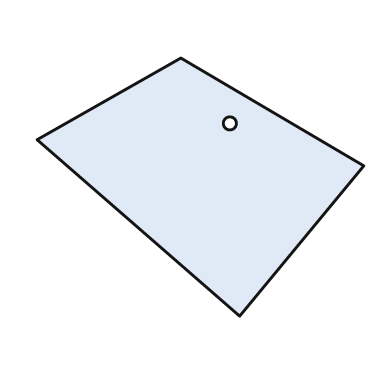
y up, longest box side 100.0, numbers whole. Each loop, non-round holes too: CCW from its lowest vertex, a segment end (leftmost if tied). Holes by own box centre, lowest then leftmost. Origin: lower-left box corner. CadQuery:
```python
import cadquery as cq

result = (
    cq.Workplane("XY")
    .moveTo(62.0, 0.0)
    .lineTo(100.0, 46.0)
    .lineTo(44.0, 79.0)
    .lineTo(0.0, 54.0)
    .close()
    .moveTo(59.0, 59.0)
    .circle(2.0)
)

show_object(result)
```